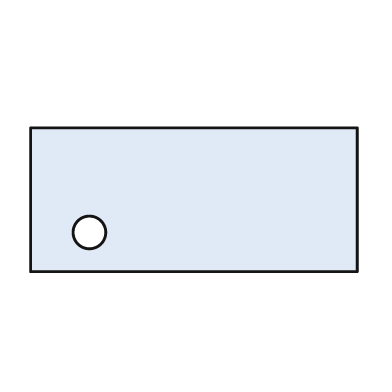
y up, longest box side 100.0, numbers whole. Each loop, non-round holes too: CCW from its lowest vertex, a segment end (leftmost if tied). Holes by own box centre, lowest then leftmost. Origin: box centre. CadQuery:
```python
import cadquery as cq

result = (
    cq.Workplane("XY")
    .moveTo(-50.0, -22.0)
    .lineTo(50.0, -22.0)
    .lineTo(50.0, 22.0)
    .lineTo(-50.0, 22.0)
    .close()
    .moveTo(-32.0, -10.0)
    .circle(5.0)
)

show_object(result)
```